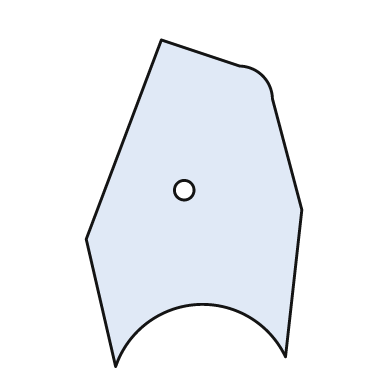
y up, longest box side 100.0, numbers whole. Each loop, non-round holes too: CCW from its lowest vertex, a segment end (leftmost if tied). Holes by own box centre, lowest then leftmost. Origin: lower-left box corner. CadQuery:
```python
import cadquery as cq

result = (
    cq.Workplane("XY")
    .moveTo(9.0, 0.0)
    .threePointArc((34.0, 19.0), (61.0, 3.0))
    .lineTo(66.0, 48.0)
    .lineTo(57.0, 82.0)
    .threePointArc((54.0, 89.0), (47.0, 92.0))
    .lineTo(23.0, 100.0)
    .lineTo(0.0, 39.0)
    .close()
    .moveTo(30.0, 54.0)
    .circle(3.0)
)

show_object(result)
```